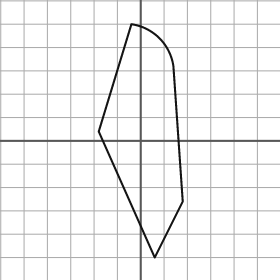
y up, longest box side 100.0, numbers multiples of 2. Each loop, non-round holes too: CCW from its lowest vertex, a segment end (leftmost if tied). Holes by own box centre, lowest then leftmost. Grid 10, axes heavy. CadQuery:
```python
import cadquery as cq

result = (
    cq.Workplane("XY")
    .moveTo(6.0, -50.0)
    .lineTo(18.0, -26.0)
    .lineTo(14.0, 32.0)
    .threePointArc((8.0, 44.0), (-4.0, 50.0))
    .lineTo(-18.0, 4.0)
    .close()
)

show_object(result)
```